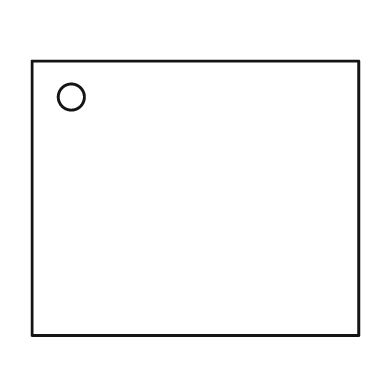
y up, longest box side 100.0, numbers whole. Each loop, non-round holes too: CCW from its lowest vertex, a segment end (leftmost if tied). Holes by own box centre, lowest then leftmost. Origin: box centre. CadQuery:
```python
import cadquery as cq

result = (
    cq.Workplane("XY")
    .moveTo(-50.0, -42.0)
    .lineTo(50.0, -42.0)
    .lineTo(50.0, 42.0)
    .lineTo(-50.0, 42.0)
    .close()
    .moveTo(-38.0, 31.0)
    .circle(4.0)
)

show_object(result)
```